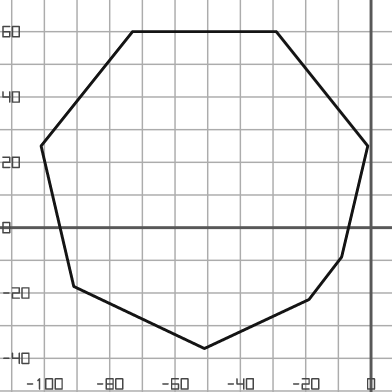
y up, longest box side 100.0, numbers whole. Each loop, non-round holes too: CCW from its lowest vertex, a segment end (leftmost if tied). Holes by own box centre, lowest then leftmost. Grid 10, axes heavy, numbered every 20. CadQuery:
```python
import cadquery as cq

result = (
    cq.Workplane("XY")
    .moveTo(-51.0, -37.0)
    .lineTo(-19.0, -22.0)
    .lineTo(-9.0, -9.0)
    .lineTo(-1.0, 25.0)
    .lineTo(-29.0, 60.0)
    .lineTo(-73.0, 60.0)
    .lineTo(-101.0, 25.0)
    .lineTo(-91.0, -18.0)
    .close()
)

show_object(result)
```